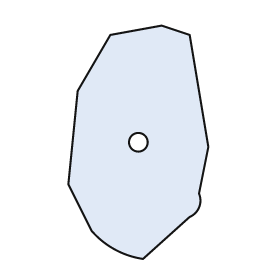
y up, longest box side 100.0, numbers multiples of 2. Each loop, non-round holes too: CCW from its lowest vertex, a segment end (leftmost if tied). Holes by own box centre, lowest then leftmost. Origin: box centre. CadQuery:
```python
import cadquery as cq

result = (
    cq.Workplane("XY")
    .moveTo(2.0, -50.0)
    .lineTo(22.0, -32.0)
    .threePointArc((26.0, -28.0), (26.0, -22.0))
    .lineTo(30.0, -2.0)
    .lineTo(22.0, 46.0)
    .lineTo(10.0, 50.0)
    .lineTo(-12.0, 46.0)
    .lineTo(-26.0, 22.0)
    .lineTo(-30.0, -18.0)
    .lineTo(-20.0, -38.0)
    .threePointArc((-10.0, -46.0), (2.0, -50.0))
    .close()
    .moveTo(0.0, 0.0)
    .circle(4.0)
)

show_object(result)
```